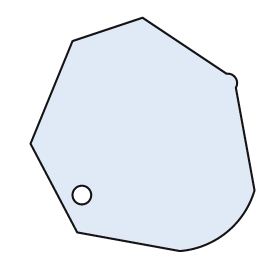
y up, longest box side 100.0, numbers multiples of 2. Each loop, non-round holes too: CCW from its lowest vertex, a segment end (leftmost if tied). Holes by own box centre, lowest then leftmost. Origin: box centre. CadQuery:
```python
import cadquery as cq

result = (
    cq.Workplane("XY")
    .moveTo(16.0, -50.0)
    .threePointArc((36.0, -42.0), (48.0, -24.0))
    .lineTo(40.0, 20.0)
    .threePointArc((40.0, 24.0), (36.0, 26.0))
    .lineTo(0.0, 50.0)
    .lineTo(-30.0, 40.0)
    .lineTo(-48.0, -4.0)
    .lineTo(-28.0, -42.0)
    .close()
    .moveTo(-26.0, -26.0)
    .circle(4.0)
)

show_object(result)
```